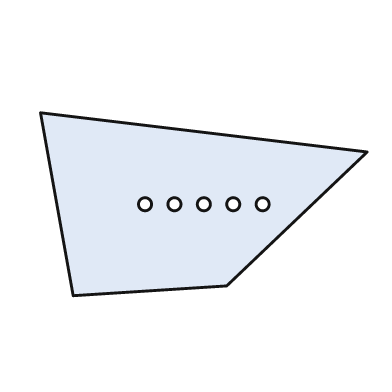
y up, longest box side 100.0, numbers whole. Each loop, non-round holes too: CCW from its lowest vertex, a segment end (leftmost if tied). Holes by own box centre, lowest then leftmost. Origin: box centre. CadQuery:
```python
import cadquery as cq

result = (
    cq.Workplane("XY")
    .moveTo(-40.0, -28.0)
    .lineTo(7.0, -25.0)
    .lineTo(50.0, 16.0)
    .lineTo(-50.0, 28.0)
    .close()
    .moveTo(-18.0, 0.0)
    .circle(2.0)
    .moveTo(-9.0, 0.0)
    .circle(2.0)
    .moveTo(0.0, 0.0)
    .circle(2.0)
    .moveTo(9.0, 0.0)
    .circle(2.0)
    .moveTo(18.0, 0.0)
    .circle(2.0)
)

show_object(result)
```